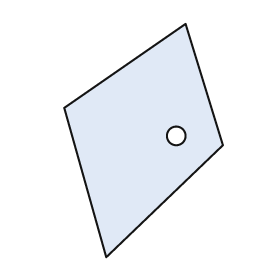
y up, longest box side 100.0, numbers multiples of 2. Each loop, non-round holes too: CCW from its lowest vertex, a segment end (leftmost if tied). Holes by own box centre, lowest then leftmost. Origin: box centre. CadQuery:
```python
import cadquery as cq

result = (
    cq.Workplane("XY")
    .moveTo(-16.0, -50.0)
    .lineTo(34.0, -2.0)
    .lineTo(18.0, 50.0)
    .lineTo(-34.0, 14.0)
    .close()
    .moveTo(14.0, 2.0)
    .circle(4.0)
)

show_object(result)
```